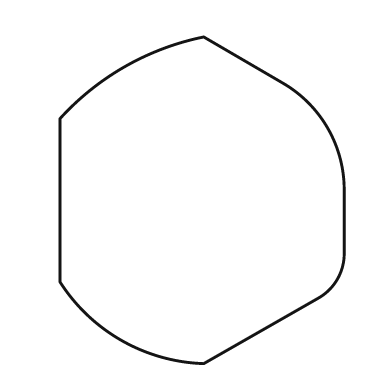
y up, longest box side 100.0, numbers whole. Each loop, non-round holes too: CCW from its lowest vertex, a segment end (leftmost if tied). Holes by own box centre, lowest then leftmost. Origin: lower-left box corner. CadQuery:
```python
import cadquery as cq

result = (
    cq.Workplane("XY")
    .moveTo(44.0, 0.0)
    .lineTo(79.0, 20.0)
    .threePointArc((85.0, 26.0), (87.0, 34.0))
    .lineTo(87.0, 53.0)
    .threePointArc((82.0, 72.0), (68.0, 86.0))
    .lineTo(44.0, 100.0)
    .threePointArc((20.0, 91.0), (0.0, 75.0))
    .lineTo(0.0, 25.0)
    .threePointArc((19.0, 7.0), (44.0, 0.0))
    .close()
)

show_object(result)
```